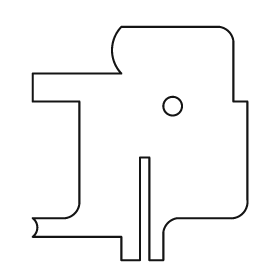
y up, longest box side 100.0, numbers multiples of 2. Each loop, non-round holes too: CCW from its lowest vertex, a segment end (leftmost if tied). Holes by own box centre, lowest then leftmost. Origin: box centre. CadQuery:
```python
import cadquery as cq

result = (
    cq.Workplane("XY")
    .moveTo(-8.0, -50.0)
    .lineTo(0.0, -50.0)
    .lineTo(0.0, -6.0)
    .lineTo(4.0, -6.0)
    .lineTo(4.0, -50.0)
    .lineTo(10.0, -50.0)
    .lineTo(10.0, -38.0)
    .threePointArc((12.0, -34.0), (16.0, -32.0))
    .lineTo(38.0, -32.0)
    .threePointArc((44.0, -30.0), (46.0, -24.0))
    .lineTo(46.0, 18.0)
    .lineTo(40.0, 18.0)
    .lineTo(40.0, 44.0)
    .threePointArc((38.0, 48.0), (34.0, 50.0))
    .lineTo(-8.0, 50.0)
    .threePointArc((-12.0, 40.0), (-8.0, 30.0))
    .lineTo(-46.0, 30.0)
    .lineTo(-46.0, 18.0)
    .lineTo(-26.0, 18.0)
    .lineTo(-26.0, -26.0)
    .threePointArc((-28.0, -30.0), (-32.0, -32.0))
    .lineTo(-46.0, -32.0)
    .threePointArc((-44.0, -36.0), (-46.0, -40.0))
    .lineTo(-8.0, -40.0)
    .close()
    .moveTo(14.0, 16.0)
    .circle(4.0)
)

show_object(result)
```